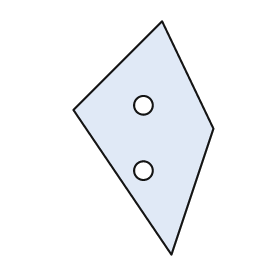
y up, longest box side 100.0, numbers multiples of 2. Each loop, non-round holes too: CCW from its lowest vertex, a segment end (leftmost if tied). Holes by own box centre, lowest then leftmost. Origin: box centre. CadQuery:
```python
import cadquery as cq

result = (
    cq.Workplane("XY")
    .moveTo(12.0, -50.0)
    .lineTo(30.0, 4.0)
    .lineTo(8.0, 50.0)
    .lineTo(-30.0, 12.0)
    .close()
    .moveTo(0.0, -14.0)
    .circle(4.0)
    .moveTo(0.0, 14.0)
    .circle(4.0)
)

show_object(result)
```